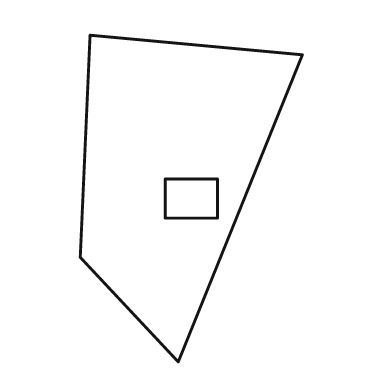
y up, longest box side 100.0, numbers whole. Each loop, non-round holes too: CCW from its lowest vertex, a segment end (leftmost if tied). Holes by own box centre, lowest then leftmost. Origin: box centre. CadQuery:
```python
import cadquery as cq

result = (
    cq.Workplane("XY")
    .moveTo(-4.0, -50.0)
    .lineTo(34.0, 44.0)
    .lineTo(-31.0, 50.0)
    .lineTo(-34.0, -18.0)
    .close()
    .moveTo(-8.0, -6.0)
    .lineTo(8.0, -6.0)
    .lineTo(8.0, 6.0)
    .lineTo(-8.0, 6.0)
    .close()
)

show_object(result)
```